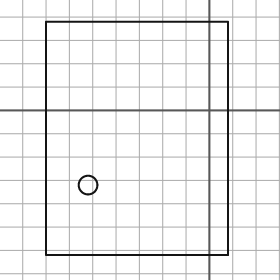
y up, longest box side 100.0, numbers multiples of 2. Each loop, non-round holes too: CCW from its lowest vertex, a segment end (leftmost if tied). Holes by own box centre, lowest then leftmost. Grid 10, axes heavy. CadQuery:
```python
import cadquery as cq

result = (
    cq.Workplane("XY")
    .moveTo(-70.0, -62.0)
    .lineTo(8.0, -62.0)
    .lineTo(8.0, 38.0)
    .lineTo(-70.0, 38.0)
    .close()
    .moveTo(-52.0, -32.0)
    .circle(4.0)
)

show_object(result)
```